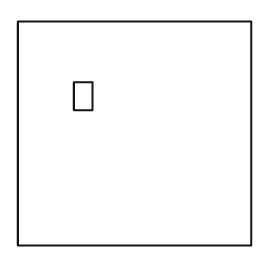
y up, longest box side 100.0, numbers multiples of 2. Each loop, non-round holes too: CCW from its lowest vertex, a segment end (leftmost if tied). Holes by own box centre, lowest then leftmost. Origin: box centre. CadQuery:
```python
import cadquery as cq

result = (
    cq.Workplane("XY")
    .moveTo(-50.0, -48.0)
    .lineTo(50.0, -48.0)
    .lineTo(50.0, 48.0)
    .lineTo(-50.0, 48.0)
    .close()
    .moveTo(-26.0, 10.0)
    .lineTo(-18.0, 10.0)
    .lineTo(-18.0, 22.0)
    .lineTo(-26.0, 22.0)
    .close()
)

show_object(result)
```